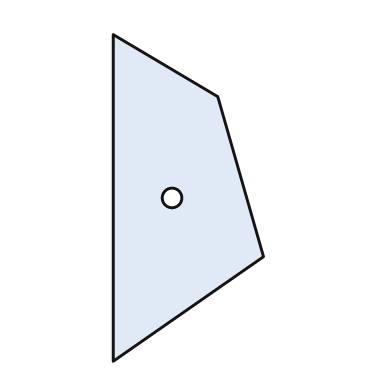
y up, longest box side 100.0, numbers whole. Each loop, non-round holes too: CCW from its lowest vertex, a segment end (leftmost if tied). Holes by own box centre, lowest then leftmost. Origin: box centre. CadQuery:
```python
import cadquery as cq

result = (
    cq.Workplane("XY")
    .moveTo(-23.0, -50.0)
    .lineTo(23.0, -18.0)
    .lineTo(9.0, 31.0)
    .lineTo(-23.0, 50.0)
    .close()
    .moveTo(-5.0, 0.0)
    .circle(3.0)
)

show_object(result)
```